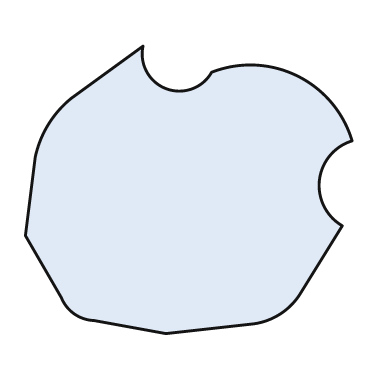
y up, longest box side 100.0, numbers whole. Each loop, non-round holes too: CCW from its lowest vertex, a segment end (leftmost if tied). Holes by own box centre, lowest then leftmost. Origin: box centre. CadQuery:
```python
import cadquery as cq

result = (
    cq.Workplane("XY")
    .moveTo(-7.0, -44.0)
    .lineTo(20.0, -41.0)
    .threePointArc((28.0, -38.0), (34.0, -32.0))
    .lineTo(47.0, -11.0)
    .threePointArc((40.0, 3.0), (50.0, 15.0))
    .threePointArc((33.0, 35.0), (7.0, 36.0))
    .threePointArc((-7.0, 31.0), (-14.0, 44.0))
    .lineTo(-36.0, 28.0)
    .threePointArc((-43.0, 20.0), (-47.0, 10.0))
    .lineTo(-50.0, -14.0)
    .lineTo(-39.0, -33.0)
    .threePointArc((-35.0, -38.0), (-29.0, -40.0))
    .close()
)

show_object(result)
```